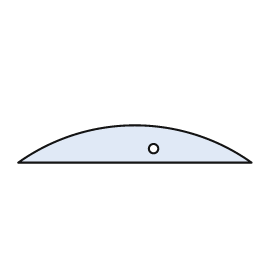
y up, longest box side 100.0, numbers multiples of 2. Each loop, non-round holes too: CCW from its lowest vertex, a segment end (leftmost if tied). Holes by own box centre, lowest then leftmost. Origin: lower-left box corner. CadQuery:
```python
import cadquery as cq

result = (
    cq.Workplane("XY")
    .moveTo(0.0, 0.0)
    .lineTo(100.0, 0.0)
    .threePointArc((50.0, 16.0), (0.0, 0.0))
    .close()
    .moveTo(58.0, 6.0)
    .circle(2.0)
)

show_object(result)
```